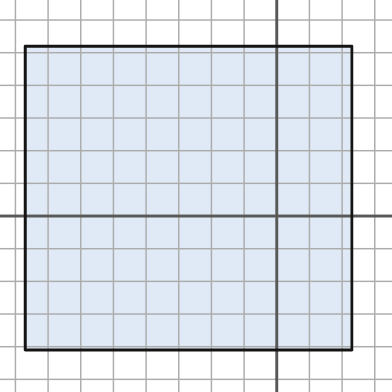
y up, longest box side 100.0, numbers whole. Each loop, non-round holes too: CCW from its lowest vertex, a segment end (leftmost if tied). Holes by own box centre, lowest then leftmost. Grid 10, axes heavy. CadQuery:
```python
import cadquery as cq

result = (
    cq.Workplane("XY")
    .moveTo(-77.0, -41.0)
    .lineTo(23.0, -41.0)
    .lineTo(23.0, 52.0)
    .lineTo(-77.0, 52.0)
    .close()
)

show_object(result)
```